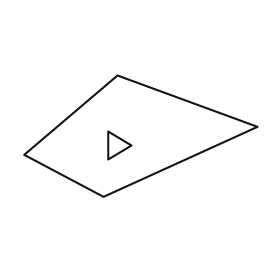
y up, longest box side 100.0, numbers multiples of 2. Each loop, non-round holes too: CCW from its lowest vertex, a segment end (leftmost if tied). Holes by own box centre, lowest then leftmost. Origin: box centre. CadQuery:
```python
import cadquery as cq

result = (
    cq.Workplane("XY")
    .moveTo(-16.0, -26.0)
    .lineTo(50.0, 4.0)
    .lineTo(-10.0, 26.0)
    .lineTo(-50.0, -8.0)
    .close()
    .moveTo(-14.0, -10.0)
    .lineTo(-4.0, -4.0)
    .lineTo(-14.0, 2.0)
    .close()
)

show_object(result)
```